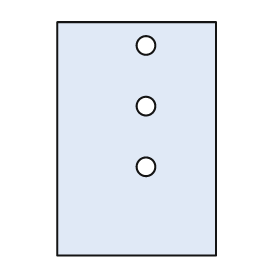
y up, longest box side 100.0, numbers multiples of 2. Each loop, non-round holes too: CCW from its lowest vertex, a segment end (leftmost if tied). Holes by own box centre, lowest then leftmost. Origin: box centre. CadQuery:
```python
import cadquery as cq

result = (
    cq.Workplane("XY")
    .moveTo(-34.0, -50.0)
    .lineTo(34.0, -50.0)
    .lineTo(34.0, 50.0)
    .lineTo(-34.0, 50.0)
    .close()
    .moveTo(4.0, -12.0)
    .circle(4.0)
    .moveTo(4.0, 14.0)
    .circle(4.0)
    .moveTo(4.0, 40.0)
    .circle(4.0)
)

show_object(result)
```